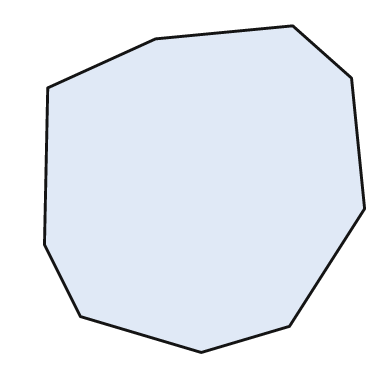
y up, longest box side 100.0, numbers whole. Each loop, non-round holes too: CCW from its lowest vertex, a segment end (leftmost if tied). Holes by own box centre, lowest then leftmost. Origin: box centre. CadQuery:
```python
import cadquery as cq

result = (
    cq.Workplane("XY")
    .moveTo(-1.0, -50.0)
    .lineTo(26.0, -42.0)
    .lineTo(49.0, -6.0)
    .lineTo(45.0, 34.0)
    .lineTo(27.0, 50.0)
    .lineTo(-15.0, 46.0)
    .lineTo(-48.0, 31.0)
    .lineTo(-49.0, -17.0)
    .lineTo(-38.0, -39.0)
    .close()
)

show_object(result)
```